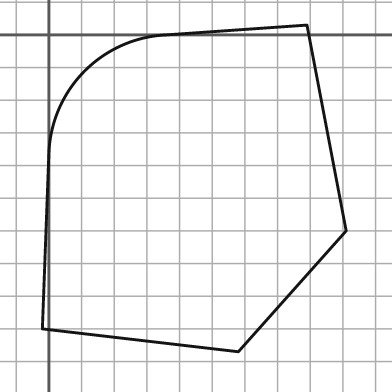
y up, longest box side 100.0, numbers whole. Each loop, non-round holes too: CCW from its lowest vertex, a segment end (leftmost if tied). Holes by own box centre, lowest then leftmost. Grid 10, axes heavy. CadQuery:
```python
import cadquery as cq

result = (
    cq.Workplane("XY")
    .moveTo(58.0, -97.0)
    .lineTo(91.0, -60.0)
    .lineTo(79.0, 3.0)
    .lineTo(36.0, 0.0)
    .threePointArc((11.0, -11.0), (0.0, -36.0))
    .lineTo(-2.0, -90.0)
    .close()
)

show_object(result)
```